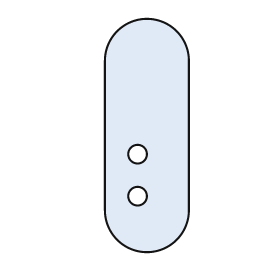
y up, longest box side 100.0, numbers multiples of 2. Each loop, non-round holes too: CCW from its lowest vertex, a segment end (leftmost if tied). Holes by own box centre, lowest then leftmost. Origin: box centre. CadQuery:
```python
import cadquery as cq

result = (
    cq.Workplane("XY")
    .moveTo(-18.0, -32.0)
    .threePointArc((0.0, -50.0), (18.0, -32.0))
    .lineTo(18.0, 32.0)
    .threePointArc((0.0, 50.0), (-18.0, 32.0))
    .close()
    .moveTo(-4.0, -26.0)
    .circle(4.0)
    .moveTo(-4.0, -8.0)
    .circle(4.0)
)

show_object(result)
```